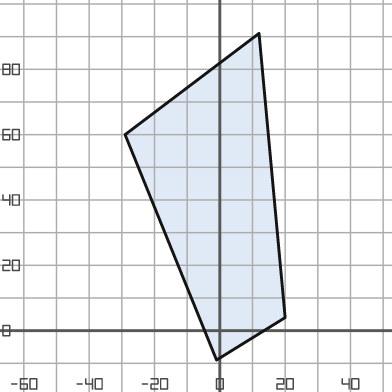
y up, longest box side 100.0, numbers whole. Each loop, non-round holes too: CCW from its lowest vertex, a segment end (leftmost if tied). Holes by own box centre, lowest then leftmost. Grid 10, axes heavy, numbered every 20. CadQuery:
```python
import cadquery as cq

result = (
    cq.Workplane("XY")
    .moveTo(-1.0, -9.0)
    .lineTo(20.0, 4.0)
    .lineTo(12.0, 91.0)
    .lineTo(-29.0, 60.0)
    .close()
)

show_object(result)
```